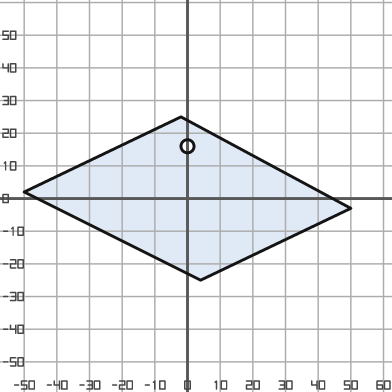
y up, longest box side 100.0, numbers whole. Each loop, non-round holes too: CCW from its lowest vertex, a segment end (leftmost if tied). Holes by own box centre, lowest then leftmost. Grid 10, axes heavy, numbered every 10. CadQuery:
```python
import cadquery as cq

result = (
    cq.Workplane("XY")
    .moveTo(4.0, -25.0)
    .lineTo(50.0, -3.0)
    .lineTo(-2.0, 25.0)
    .lineTo(-50.0, 2.0)
    .close()
    .moveTo(0.0, 16.0)
    .circle(2.0)
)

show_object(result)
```